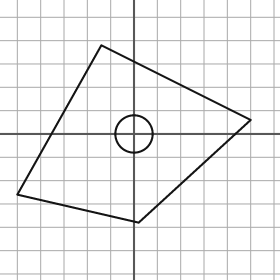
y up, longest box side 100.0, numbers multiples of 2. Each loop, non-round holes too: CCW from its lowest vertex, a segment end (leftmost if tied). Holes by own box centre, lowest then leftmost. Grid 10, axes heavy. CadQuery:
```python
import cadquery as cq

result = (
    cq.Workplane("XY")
    .moveTo(2.0, -38.0)
    .lineTo(50.0, 6.0)
    .lineTo(-14.0, 38.0)
    .lineTo(-50.0, -26.0)
    .close()
    .moveTo(0.0, 0.0)
    .circle(8.0)
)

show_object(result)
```